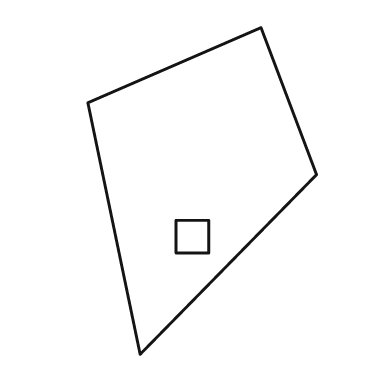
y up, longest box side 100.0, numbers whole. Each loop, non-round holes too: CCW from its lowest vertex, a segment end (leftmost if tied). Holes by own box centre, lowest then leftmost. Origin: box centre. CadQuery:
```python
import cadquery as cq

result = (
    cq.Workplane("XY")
    .moveTo(-19.0, -50.0)
    .lineTo(35.0, 5.0)
    .lineTo(18.0, 50.0)
    .lineTo(-35.0, 27.0)
    .close()
    .moveTo(-8.0, -19.0)
    .lineTo(2.0, -19.0)
    .lineTo(2.0, -9.0)
    .lineTo(-8.0, -9.0)
    .close()
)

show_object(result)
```